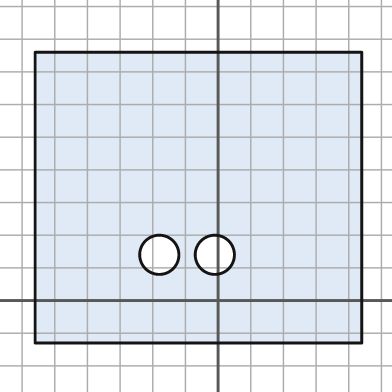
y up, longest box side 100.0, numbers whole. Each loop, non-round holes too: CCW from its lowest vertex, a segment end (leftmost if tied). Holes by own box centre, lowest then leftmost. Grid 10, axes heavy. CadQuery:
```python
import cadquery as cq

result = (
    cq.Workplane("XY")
    .moveTo(-56.0, -13.0)
    .lineTo(44.0, -13.0)
    .lineTo(44.0, 76.0)
    .lineTo(-56.0, 76.0)
    .close()
    .moveTo(-18.0, 14.0)
    .circle(6.0)
    .moveTo(-1.0, 14.0)
    .circle(6.0)
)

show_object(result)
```